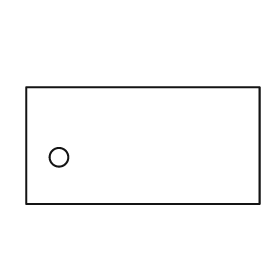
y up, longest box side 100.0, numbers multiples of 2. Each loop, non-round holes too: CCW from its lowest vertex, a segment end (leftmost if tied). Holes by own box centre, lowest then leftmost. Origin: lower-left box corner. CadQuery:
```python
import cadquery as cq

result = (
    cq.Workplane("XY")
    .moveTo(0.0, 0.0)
    .lineTo(100.0, 0.0)
    .lineTo(100.0, 50.0)
    .lineTo(0.0, 50.0)
    .close()
    .moveTo(14.0, 20.0)
    .circle(4.0)
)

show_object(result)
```